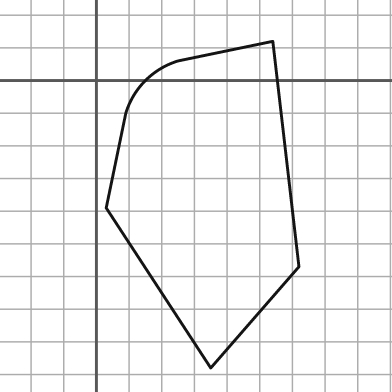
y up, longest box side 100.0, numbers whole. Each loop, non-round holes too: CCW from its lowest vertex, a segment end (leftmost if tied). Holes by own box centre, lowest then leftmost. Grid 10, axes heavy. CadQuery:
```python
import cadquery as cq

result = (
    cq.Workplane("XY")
    .moveTo(35.0, -88.0)
    .lineTo(62.0, -57.0)
    .lineTo(54.0, 12.0)
    .lineTo(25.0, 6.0)
    .threePointArc((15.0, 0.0), (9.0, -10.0))
    .lineTo(3.0, -39.0)
    .close()
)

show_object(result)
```